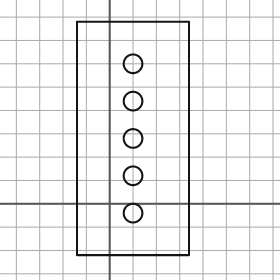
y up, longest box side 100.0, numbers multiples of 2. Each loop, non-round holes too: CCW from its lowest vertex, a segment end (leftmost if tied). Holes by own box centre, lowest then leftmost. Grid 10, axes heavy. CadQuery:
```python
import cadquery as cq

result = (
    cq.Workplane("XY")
    .moveTo(-14.0, -22.0)
    .lineTo(34.0, -22.0)
    .lineTo(34.0, 78.0)
    .lineTo(-14.0, 78.0)
    .close()
    .moveTo(10.0, -4.0)
    .circle(4.0)
    .moveTo(10.0, 12.0)
    .circle(4.0)
    .moveTo(10.0, 28.0)
    .circle(4.0)
    .moveTo(10.0, 44.0)
    .circle(4.0)
    .moveTo(10.0, 60.0)
    .circle(4.0)
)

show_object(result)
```